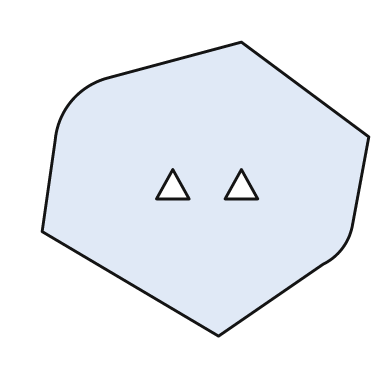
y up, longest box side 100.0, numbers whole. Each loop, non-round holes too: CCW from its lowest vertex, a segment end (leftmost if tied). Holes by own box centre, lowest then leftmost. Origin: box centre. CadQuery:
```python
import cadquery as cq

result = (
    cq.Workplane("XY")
    .moveTo(4.0, -45.0)
    .lineTo(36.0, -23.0)
    .threePointArc((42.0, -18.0), (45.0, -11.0))
    .lineTo(50.0, 16.0)
    .lineTo(11.0, 45.0)
    .lineTo(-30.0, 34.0)
    .threePointArc((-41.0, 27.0), (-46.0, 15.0))
    .lineTo(-50.0, -13.0)
    .close()
    .moveTo(-15.0, -3.0)
    .lineTo(-5.0, -3.0)
    .lineTo(-10.0, 6.0)
    .close()
    .moveTo(6.0, -3.0)
    .lineTo(16.0, -3.0)
    .lineTo(11.0, 6.0)
    .close()
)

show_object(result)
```